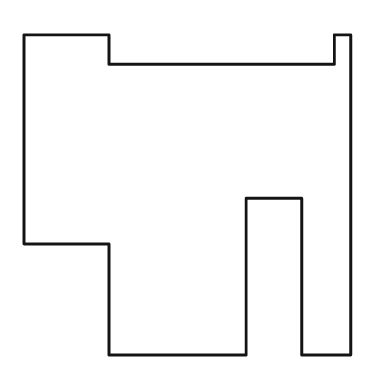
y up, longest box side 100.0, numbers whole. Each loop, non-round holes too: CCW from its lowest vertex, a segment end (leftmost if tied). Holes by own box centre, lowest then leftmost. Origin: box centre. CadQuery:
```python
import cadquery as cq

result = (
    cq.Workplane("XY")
    .moveTo(-24.0, -49.0)
    .lineTo(18.0, -49.0)
    .lineTo(18.0, -1.0)
    .lineTo(35.0, -1.0)
    .lineTo(35.0, -49.0)
    .lineTo(50.0, -49.0)
    .lineTo(50.0, 49.0)
    .lineTo(45.0, 49.0)
    .lineTo(45.0, 40.0)
    .lineTo(-24.0, 40.0)
    .lineTo(-24.0, 49.0)
    .lineTo(-50.0, 49.0)
    .lineTo(-50.0, -15.0)
    .lineTo(-24.0, -15.0)
    .close()
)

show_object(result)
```